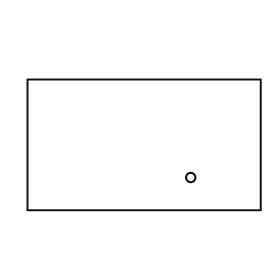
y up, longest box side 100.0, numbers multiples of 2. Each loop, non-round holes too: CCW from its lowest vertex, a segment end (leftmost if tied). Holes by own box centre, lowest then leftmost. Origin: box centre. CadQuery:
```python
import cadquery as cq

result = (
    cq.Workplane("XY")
    .moveTo(-50.0, -28.0)
    .lineTo(50.0, -28.0)
    .lineTo(50.0, 28.0)
    .lineTo(-50.0, 28.0)
    .close()
    .moveTo(20.0, -14.0)
    .circle(2.0)
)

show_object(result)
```